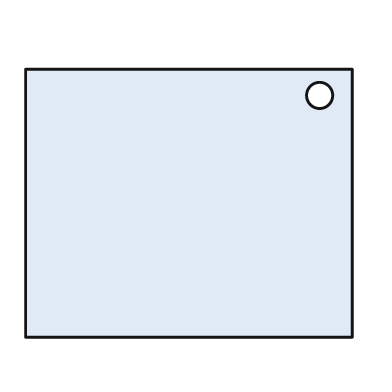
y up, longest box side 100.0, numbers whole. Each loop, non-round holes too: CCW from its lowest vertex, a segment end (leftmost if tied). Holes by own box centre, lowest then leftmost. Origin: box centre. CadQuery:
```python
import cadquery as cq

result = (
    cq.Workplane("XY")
    .moveTo(-50.0, -41.0)
    .lineTo(50.0, -41.0)
    .lineTo(50.0, 41.0)
    .lineTo(-50.0, 41.0)
    .close()
    .moveTo(40.0, 33.0)
    .circle(4.0)
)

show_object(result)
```